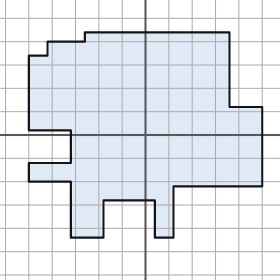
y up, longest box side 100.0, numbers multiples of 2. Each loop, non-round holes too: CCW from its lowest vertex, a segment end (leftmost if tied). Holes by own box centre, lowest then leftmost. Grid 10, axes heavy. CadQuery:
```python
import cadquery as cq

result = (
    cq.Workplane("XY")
    .moveTo(-32.0, -44.0)
    .lineTo(-18.0, -44.0)
    .lineTo(-18.0, -28.0)
    .lineTo(4.0, -28.0)
    .lineTo(4.0, -44.0)
    .lineTo(12.0, -44.0)
    .lineTo(12.0, -22.0)
    .lineTo(50.0, -22.0)
    .lineTo(50.0, 12.0)
    .lineTo(36.0, 12.0)
    .lineTo(36.0, 44.0)
    .lineTo(-26.0, 44.0)
    .lineTo(-26.0, 40.0)
    .lineTo(-42.0, 40.0)
    .lineTo(-42.0, 34.0)
    .lineTo(-50.0, 34.0)
    .lineTo(-50.0, 2.0)
    .lineTo(-32.0, 2.0)
    .lineTo(-32.0, -12.0)
    .lineTo(-50.0, -12.0)
    .lineTo(-50.0, -20.0)
    .lineTo(-32.0, -20.0)
    .close()
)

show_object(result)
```